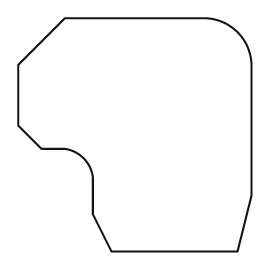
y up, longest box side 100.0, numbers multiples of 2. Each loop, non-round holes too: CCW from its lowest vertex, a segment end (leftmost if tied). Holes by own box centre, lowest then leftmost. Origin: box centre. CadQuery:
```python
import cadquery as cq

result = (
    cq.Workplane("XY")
    .moveTo(-10.0, -50.0)
    .lineTo(44.0, -50.0)
    .lineTo(50.0, -26.0)
    .lineTo(50.0, 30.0)
    .threePointArc((44.0, 44.0), (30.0, 50.0))
    .lineTo(-30.0, 50.0)
    .lineTo(-50.0, 30.0)
    .lineTo(-50.0, 4.0)
    .lineTo(-40.0, -6.0)
    .lineTo(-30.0, -6.0)
    .threePointArc((-22.0, -10.0), (-18.0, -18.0))
    .lineTo(-18.0, -34.0)
    .close()
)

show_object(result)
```